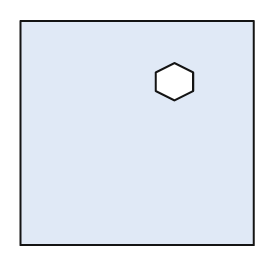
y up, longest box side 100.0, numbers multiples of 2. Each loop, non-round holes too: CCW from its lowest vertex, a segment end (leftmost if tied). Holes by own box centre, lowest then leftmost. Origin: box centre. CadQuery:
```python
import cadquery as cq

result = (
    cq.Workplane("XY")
    .moveTo(-50.0, -48.0)
    .lineTo(50.0, -48.0)
    .lineTo(50.0, 48.0)
    .lineTo(-50.0, 48.0)
    .close()
    .moveTo(16.0, 14.0)
    .lineTo(24.0, 18.0)
    .lineTo(24.0, 26.0)
    .lineTo(16.0, 30.0)
    .lineTo(8.0, 26.0)
    .lineTo(8.0, 18.0)
    .close()
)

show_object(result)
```